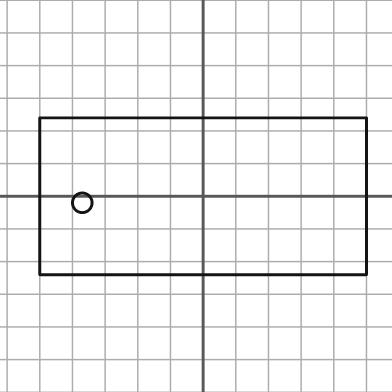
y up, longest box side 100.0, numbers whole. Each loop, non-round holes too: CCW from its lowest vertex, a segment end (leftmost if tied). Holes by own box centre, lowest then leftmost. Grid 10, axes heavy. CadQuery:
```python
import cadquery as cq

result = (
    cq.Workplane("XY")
    .moveTo(-50.0, -24.0)
    .lineTo(50.0, -24.0)
    .lineTo(50.0, 24.0)
    .lineTo(-50.0, 24.0)
    .close()
    .moveTo(-37.0, -2.0)
    .circle(3.0)
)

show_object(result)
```